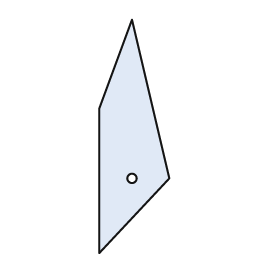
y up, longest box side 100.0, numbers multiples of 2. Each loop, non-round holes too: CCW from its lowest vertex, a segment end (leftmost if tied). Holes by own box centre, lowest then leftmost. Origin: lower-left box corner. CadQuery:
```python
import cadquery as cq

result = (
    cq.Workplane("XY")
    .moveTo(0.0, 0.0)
    .lineTo(30.0, 32.0)
    .lineTo(14.0, 100.0)
    .lineTo(0.0, 62.0)
    .close()
    .moveTo(14.0, 32.0)
    .circle(2.0)
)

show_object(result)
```